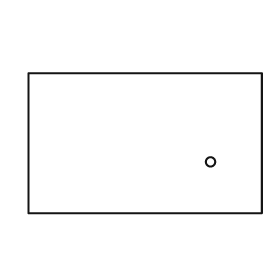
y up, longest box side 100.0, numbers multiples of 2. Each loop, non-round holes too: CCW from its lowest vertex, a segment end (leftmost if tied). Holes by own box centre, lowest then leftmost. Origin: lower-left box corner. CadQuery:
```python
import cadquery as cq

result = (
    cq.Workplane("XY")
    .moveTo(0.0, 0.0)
    .lineTo(100.0, 0.0)
    .lineTo(100.0, 60.0)
    .lineTo(0.0, 60.0)
    .close()
    .moveTo(78.0, 22.0)
    .circle(2.0)
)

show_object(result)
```